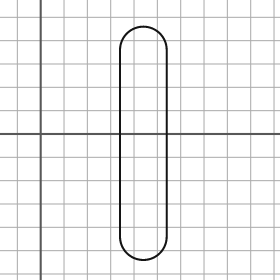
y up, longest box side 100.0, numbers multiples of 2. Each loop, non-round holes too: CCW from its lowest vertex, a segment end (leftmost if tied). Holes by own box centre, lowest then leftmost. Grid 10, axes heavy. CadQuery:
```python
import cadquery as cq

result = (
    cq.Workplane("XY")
    .moveTo(34.0, -44.0)
    .threePointArc((44.0, -54.0), (54.0, -44.0))
    .lineTo(54.0, 36.0)
    .threePointArc((44.0, 46.0), (34.0, 36.0))
    .close()
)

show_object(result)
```